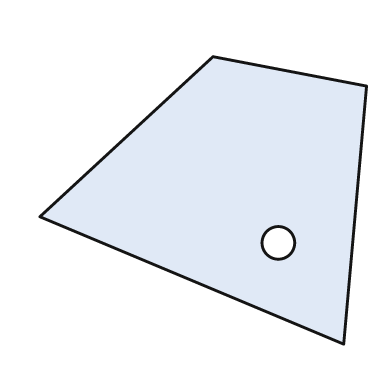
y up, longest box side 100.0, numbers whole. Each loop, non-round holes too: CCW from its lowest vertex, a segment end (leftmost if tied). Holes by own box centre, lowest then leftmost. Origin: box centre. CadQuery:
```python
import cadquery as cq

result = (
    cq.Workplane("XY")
    .moveTo(43.0, -44.0)
    .lineTo(50.0, 35.0)
    .lineTo(3.0, 44.0)
    .lineTo(-50.0, -5.0)
    .close()
    .moveTo(23.0, -13.0)
    .circle(5.0)
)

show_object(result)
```